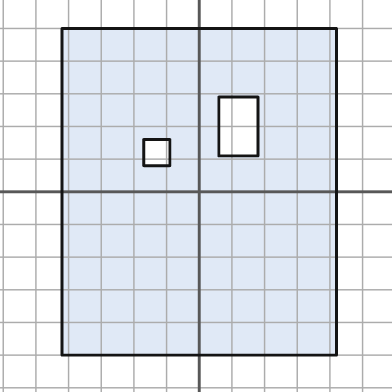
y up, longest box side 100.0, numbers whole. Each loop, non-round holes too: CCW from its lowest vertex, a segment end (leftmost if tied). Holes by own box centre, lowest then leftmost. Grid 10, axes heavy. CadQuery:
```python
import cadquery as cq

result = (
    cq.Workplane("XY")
    .moveTo(-42.0, -50.0)
    .lineTo(42.0, -50.0)
    .lineTo(42.0, 50.0)
    .lineTo(-42.0, 50.0)
    .close()
    .moveTo(-17.0, 8.0)
    .lineTo(-9.0, 8.0)
    .lineTo(-9.0, 16.0)
    .lineTo(-17.0, 16.0)
    .close()
    .moveTo(6.0, 11.0)
    .lineTo(18.0, 11.0)
    .lineTo(18.0, 29.0)
    .lineTo(6.0, 29.0)
    .close()
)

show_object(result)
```